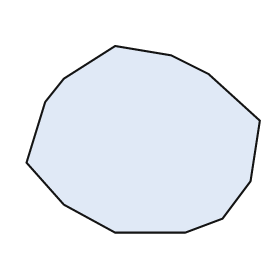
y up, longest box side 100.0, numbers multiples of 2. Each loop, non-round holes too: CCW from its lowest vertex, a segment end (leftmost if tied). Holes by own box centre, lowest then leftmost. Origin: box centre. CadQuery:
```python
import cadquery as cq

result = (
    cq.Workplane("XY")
    .moveTo(-12.0, -40.0)
    .lineTo(18.0, -40.0)
    .lineTo(34.0, -34.0)
    .lineTo(46.0, -18.0)
    .lineTo(50.0, 8.0)
    .lineTo(28.0, 28.0)
    .lineTo(12.0, 36.0)
    .lineTo(-12.0, 40.0)
    .lineTo(-34.0, 26.0)
    .lineTo(-42.0, 16.0)
    .lineTo(-50.0, -10.0)
    .lineTo(-34.0, -28.0)
    .close()
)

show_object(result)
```